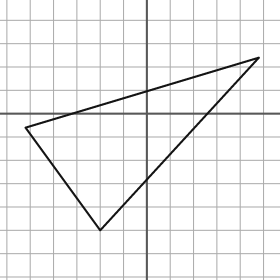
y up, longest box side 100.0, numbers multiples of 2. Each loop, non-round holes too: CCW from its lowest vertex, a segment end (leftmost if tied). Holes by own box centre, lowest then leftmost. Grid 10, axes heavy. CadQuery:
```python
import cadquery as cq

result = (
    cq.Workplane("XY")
    .moveTo(-20.0, -50.0)
    .lineTo(48.0, 24.0)
    .lineTo(-52.0, -6.0)
    .close()
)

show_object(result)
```